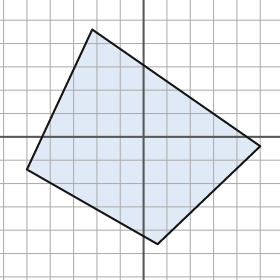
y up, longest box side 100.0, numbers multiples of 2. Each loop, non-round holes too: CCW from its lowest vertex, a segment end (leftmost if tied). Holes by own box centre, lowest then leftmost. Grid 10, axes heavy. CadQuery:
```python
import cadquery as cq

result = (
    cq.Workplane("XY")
    .moveTo(6.0, -46.0)
    .lineTo(50.0, -4.0)
    .lineTo(-22.0, 46.0)
    .lineTo(-50.0, -14.0)
    .close()
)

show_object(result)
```